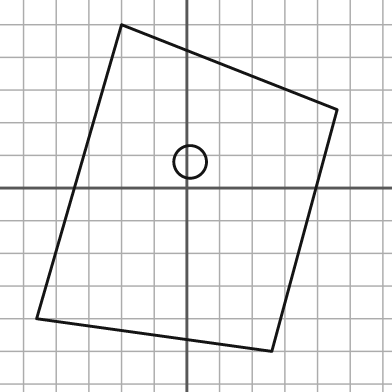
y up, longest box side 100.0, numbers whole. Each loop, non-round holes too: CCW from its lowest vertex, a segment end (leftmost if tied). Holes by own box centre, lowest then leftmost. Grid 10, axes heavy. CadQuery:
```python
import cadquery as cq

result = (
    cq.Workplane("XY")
    .moveTo(26.0, -50.0)
    .lineTo(46.0, 24.0)
    .lineTo(-20.0, 50.0)
    .lineTo(-46.0, -40.0)
    .close()
    .moveTo(1.0, 8.0)
    .circle(5.0)
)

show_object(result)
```